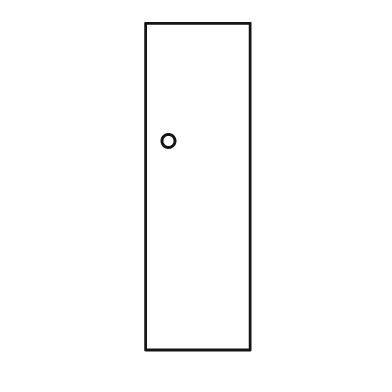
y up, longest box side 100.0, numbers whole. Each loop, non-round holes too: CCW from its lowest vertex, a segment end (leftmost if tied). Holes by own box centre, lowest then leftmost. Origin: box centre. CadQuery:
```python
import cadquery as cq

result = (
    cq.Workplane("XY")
    .moveTo(-16.0, -50.0)
    .lineTo(16.0, -50.0)
    .lineTo(16.0, 50.0)
    .lineTo(-16.0, 50.0)
    .close()
    .moveTo(-9.0, 14.0)
    .circle(2.0)
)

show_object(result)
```